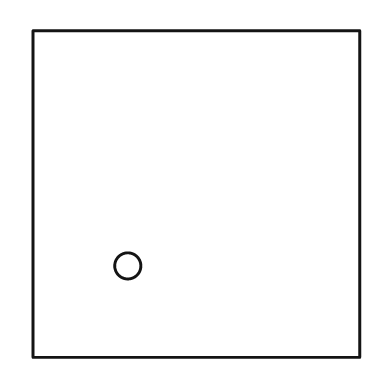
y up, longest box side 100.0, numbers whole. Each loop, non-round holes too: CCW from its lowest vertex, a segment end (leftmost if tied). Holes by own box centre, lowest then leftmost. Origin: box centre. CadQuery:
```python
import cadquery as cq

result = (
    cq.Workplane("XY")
    .moveTo(-50.0, -50.0)
    .lineTo(50.0, -50.0)
    .lineTo(50.0, 50.0)
    .lineTo(-50.0, 50.0)
    .close()
    .moveTo(-21.0, -22.0)
    .circle(4.0)
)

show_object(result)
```